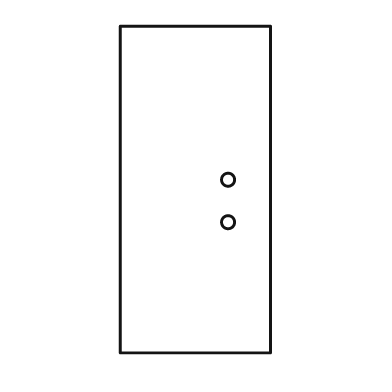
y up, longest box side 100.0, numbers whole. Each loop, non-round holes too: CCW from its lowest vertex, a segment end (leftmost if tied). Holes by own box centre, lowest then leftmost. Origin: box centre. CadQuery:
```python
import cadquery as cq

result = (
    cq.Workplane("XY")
    .moveTo(-23.0, -50.0)
    .lineTo(23.0, -50.0)
    .lineTo(23.0, 50.0)
    .lineTo(-23.0, 50.0)
    .close()
    .moveTo(10.0, -10.0)
    .circle(2.0)
    .moveTo(10.0, 3.0)
    .circle(2.0)
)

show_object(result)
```